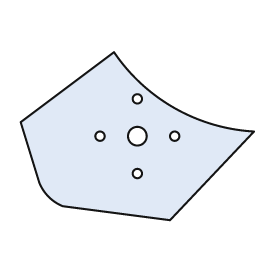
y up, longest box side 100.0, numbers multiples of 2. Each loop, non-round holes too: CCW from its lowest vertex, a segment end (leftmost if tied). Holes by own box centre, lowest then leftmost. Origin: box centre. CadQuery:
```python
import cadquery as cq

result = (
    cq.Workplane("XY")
    .moveTo(14.0, -36.0)
    .lineTo(50.0, 2.0)
    .threePointArc((16.0, 12.0), (-10.0, 36.0))
    .lineTo(-50.0, 6.0)
    .lineTo(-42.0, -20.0)
    .threePointArc((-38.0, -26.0), (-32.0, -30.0))
    .close()
    .moveTo(0.0, -16.0)
    .circle(2.0)
    .moveTo(-16.0, 0.0)
    .circle(2.0)
    .moveTo(0.0, 0.0)
    .circle(4.0)
    .moveTo(16.0, 0.0)
    .circle(2.0)
    .moveTo(0.0, 16.0)
    .circle(2.0)
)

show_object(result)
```